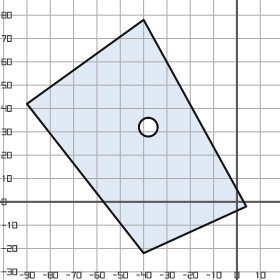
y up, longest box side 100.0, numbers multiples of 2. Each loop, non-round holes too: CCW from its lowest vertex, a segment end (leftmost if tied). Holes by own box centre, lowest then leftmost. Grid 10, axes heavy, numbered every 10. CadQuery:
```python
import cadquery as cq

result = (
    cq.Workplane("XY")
    .moveTo(-40.0, -22.0)
    .lineTo(4.0, -2.0)
    .lineTo(-40.0, 78.0)
    .lineTo(-90.0, 42.0)
    .close()
    .moveTo(-38.0, 32.0)
    .circle(4.0)
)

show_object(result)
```